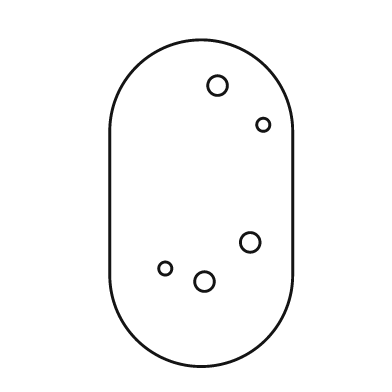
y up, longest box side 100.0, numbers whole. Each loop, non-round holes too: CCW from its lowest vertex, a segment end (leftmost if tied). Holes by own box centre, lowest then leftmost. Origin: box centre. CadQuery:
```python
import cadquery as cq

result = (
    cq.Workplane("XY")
    .moveTo(-28.0, -22.0)
    .threePointArc((0.0, -50.0), (28.0, -22.0))
    .lineTo(28.0, 22.0)
    .threePointArc((0.0, 50.0), (-28.0, 22.0))
    .close()
    .moveTo(1.0, -24.0)
    .circle(3.0)
    .moveTo(-11.0, -20.0)
    .circle(2.0)
    .moveTo(15.0, -12.0)
    .circle(3.0)
    .moveTo(19.0, 24.0)
    .circle(2.0)
    .moveTo(5.0, 36.0)
    .circle(3.0)
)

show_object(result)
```